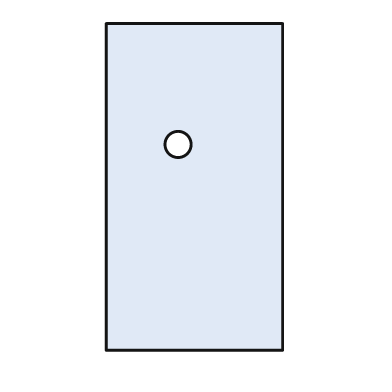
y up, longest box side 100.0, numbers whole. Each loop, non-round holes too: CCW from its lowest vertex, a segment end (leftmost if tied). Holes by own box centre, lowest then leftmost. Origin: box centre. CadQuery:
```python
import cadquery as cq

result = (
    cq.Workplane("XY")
    .moveTo(-27.0, -50.0)
    .lineTo(27.0, -50.0)
    .lineTo(27.0, 50.0)
    .lineTo(-27.0, 50.0)
    .close()
    .moveTo(-5.0, 13.0)
    .circle(4.0)
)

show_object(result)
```